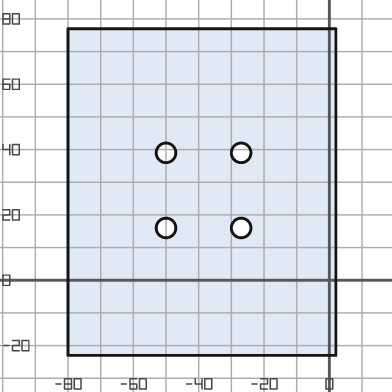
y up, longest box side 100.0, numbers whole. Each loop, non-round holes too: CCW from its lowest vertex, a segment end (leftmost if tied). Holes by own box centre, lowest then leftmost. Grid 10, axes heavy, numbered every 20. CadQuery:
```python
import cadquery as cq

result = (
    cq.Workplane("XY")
    .moveTo(-80.0, -23.0)
    .lineTo(2.0, -23.0)
    .lineTo(2.0, 77.0)
    .lineTo(-80.0, 77.0)
    .close()
    .moveTo(-50.0, 16.0)
    .circle(3.0)
    .moveTo(-27.0, 16.0)
    .circle(3.0)
    .moveTo(-50.0, 39.0)
    .circle(3.0)
    .moveTo(-27.0, 39.0)
    .circle(3.0)
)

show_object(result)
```